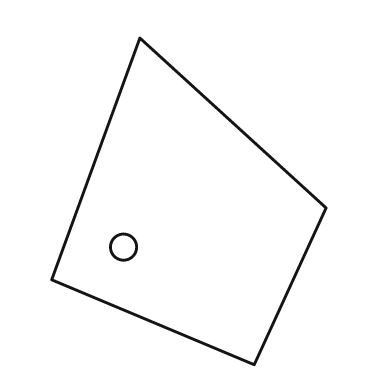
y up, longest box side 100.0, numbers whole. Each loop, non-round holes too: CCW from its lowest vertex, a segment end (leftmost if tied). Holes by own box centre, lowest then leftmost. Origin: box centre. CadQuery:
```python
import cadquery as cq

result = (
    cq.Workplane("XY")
    .moveTo(20.0, -50.0)
    .lineTo(42.0, -2.0)
    .lineTo(-15.0, 50.0)
    .lineTo(-42.0, -24.0)
    .close()
    .moveTo(-20.0, -14.0)
    .circle(4.0)
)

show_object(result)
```